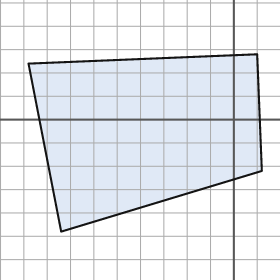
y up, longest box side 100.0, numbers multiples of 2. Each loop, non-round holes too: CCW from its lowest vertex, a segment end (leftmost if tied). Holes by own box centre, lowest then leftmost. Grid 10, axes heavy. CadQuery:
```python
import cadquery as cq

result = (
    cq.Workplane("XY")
    .moveTo(-74.0, -48.0)
    .lineTo(12.0, -22.0)
    .lineTo(10.0, 28.0)
    .lineTo(-88.0, 24.0)
    .close()
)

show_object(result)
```